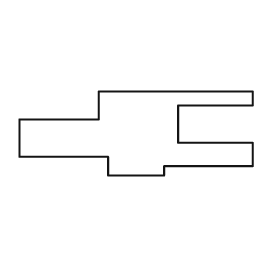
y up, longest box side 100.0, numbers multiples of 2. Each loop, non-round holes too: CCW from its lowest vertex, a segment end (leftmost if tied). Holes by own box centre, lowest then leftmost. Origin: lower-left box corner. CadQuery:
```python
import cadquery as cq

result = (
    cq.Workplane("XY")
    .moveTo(38.0, 0.0)
    .lineTo(62.0, 0.0)
    .lineTo(62.0, 4.0)
    .lineTo(100.0, 4.0)
    .lineTo(100.0, 14.0)
    .lineTo(68.0, 14.0)
    .lineTo(68.0, 30.0)
    .lineTo(100.0, 30.0)
    .lineTo(100.0, 36.0)
    .lineTo(34.0, 36.0)
    .lineTo(34.0, 24.0)
    .lineTo(0.0, 24.0)
    .lineTo(0.0, 8.0)
    .lineTo(38.0, 8.0)
    .close()
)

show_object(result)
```